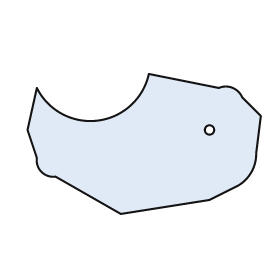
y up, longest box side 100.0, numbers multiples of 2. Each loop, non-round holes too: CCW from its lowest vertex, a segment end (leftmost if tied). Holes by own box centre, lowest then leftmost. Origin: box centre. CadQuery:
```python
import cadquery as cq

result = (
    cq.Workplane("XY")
    .moveTo(-10.0, -30.0)
    .lineTo(28.0, -24.0)
    .lineTo(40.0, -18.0)
    .threePointArc((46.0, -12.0), (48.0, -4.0))
    .lineTo(50.0, 12.0)
    .lineTo(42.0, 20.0)
    .threePointArc((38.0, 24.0), (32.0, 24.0))
    .lineTo(2.0, 30.0)
    .threePointArc((-20.0, 10.0), (-46.0, 24.0))
    .lineTo(-50.0, 6.0)
    .lineTo(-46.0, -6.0)
    .threePointArc((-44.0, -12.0), (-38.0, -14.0))
    .close()
    .moveTo(28.0, 6.0)
    .circle(2.0)
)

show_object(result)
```